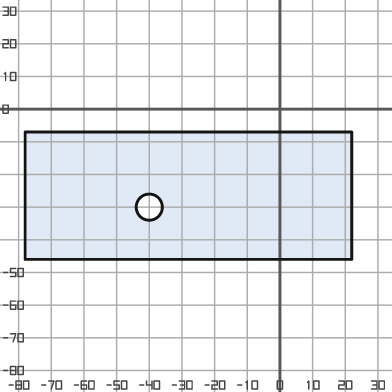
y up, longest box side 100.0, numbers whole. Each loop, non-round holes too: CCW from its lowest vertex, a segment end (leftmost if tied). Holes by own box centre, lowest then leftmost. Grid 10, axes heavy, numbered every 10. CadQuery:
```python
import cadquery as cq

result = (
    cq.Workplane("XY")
    .moveTo(-78.0, -46.0)
    .lineTo(22.0, -46.0)
    .lineTo(22.0, -7.0)
    .lineTo(-78.0, -7.0)
    .close()
    .moveTo(-40.0, -30.0)
    .circle(4.0)
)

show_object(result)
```